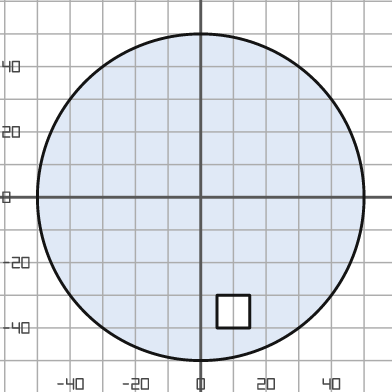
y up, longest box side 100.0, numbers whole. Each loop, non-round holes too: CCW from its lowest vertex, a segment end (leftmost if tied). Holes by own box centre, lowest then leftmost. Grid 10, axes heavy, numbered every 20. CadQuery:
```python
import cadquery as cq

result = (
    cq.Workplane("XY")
    .moveTo(0.0, 0.0)
    .circle(50.0)
    .moveTo(5.0, -40.0)
    .lineTo(15.0, -40.0)
    .lineTo(15.0, -30.0)
    .lineTo(5.0, -30.0)
    .close()
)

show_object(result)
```